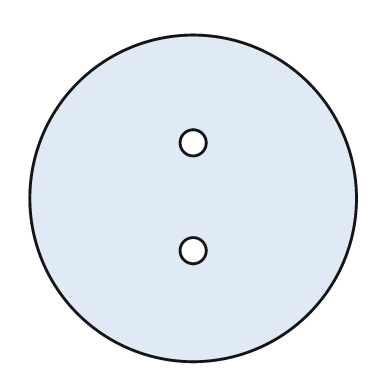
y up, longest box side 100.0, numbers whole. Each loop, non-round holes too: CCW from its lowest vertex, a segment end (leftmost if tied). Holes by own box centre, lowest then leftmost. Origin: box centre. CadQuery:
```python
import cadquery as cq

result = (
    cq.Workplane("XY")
    .moveTo(0.0, 0.0)
    .circle(50.0)
    .moveTo(0.0, -16.0)
    .circle(4.0)
    .moveTo(0.0, 17.0)
    .circle(4.0)
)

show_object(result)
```